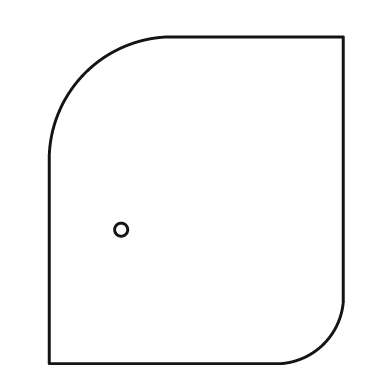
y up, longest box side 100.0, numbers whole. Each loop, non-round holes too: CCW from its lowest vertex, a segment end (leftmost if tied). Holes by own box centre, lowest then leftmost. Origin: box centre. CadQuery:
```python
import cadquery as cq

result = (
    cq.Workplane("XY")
    .moveTo(-45.0, -50.0)
    .lineTo(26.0, -50.0)
    .threePointArc((39.0, -44.0), (45.0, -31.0))
    .lineTo(45.0, 50.0)
    .lineTo(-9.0, 50.0)
    .threePointArc((-34.0, 39.0), (-45.0, 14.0))
    .close()
    .moveTo(-23.0, -9.0)
    .circle(2.0)
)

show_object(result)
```